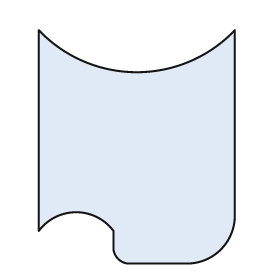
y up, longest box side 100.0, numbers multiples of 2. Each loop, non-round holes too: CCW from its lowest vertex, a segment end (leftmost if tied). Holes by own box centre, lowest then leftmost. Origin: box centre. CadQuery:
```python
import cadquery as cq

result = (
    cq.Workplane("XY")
    .moveTo(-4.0, -50.0)
    .lineTo(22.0, -50.0)
    .threePointArc((36.0, -44.0), (42.0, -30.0))
    .lineTo(42.0, 50.0)
    .threePointArc((0.0, 32.0), (-42.0, 50.0))
    .lineTo(-42.0, -36.0)
    .threePointArc((-26.0, -28.0), (-10.0, -36.0))
    .lineTo(-10.0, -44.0)
    .threePointArc((-8.0, -48.0), (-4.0, -50.0))
    .close()
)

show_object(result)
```